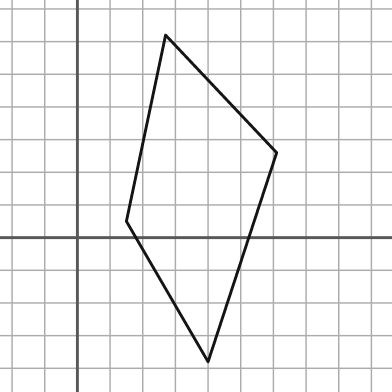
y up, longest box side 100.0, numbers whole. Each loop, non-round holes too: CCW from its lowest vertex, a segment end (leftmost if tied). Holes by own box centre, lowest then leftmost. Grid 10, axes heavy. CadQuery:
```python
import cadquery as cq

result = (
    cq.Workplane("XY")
    .moveTo(40.0, -38.0)
    .lineTo(61.0, 26.0)
    .lineTo(27.0, 62.0)
    .lineTo(15.0, 5.0)
    .close()
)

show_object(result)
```